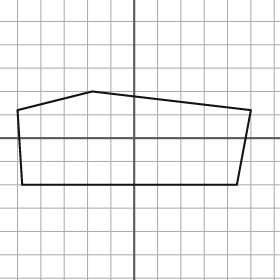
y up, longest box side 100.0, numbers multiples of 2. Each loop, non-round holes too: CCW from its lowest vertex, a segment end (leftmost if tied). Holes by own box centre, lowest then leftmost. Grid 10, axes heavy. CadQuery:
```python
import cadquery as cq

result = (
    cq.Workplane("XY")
    .moveTo(-48.0, -20.0)
    .lineTo(44.0, -20.0)
    .lineTo(50.0, 12.0)
    .lineTo(-18.0, 20.0)
    .lineTo(-50.0, 12.0)
    .close()
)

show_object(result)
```